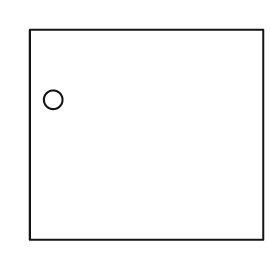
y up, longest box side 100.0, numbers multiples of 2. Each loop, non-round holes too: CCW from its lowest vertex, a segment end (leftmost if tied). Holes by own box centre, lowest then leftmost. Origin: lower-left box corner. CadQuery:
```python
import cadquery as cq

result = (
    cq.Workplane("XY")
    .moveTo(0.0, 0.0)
    .lineTo(100.0, 0.0)
    .lineTo(100.0, 90.0)
    .lineTo(0.0, 90.0)
    .close()
    .moveTo(10.0, 60.0)
    .circle(4.0)
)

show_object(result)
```